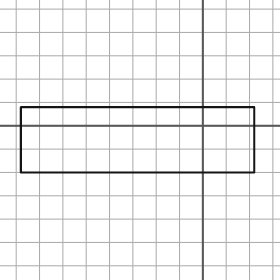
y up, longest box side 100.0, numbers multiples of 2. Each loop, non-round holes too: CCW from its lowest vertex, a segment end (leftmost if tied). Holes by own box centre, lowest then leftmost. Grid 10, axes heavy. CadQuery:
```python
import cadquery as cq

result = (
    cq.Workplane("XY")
    .moveTo(-78.0, -20.0)
    .lineTo(22.0, -20.0)
    .lineTo(22.0, 8.0)
    .lineTo(-78.0, 8.0)
    .close()
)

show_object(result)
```